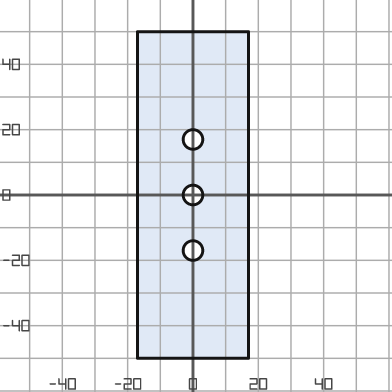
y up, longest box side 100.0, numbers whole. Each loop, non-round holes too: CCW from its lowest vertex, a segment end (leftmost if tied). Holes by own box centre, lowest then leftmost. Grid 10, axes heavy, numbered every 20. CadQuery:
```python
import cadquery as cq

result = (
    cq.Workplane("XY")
    .moveTo(-17.0, -50.0)
    .lineTo(17.0, -50.0)
    .lineTo(17.0, 50.0)
    .lineTo(-17.0, 50.0)
    .close()
    .moveTo(0.0, -17.0)
    .circle(3.0)
    .moveTo(0.0, 0.0)
    .circle(3.0)
    .moveTo(0.0, 17.0)
    .circle(3.0)
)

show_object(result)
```